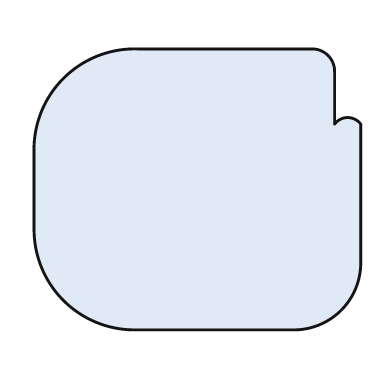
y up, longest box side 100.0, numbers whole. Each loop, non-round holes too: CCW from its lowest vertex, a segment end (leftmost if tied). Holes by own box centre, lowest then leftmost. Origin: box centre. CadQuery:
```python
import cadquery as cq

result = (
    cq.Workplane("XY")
    .moveTo(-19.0, -43.0)
    .lineTo(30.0, -43.0)
    .threePointArc((44.0, -37.0), (50.0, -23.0))
    .lineTo(50.0, 20.0)
    .threePointArc((46.0, 22.0), (42.0, 20.0))
    .lineTo(42.0, 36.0)
    .threePointArc((40.0, 41.0), (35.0, 43.0))
    .lineTo(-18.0, 43.0)
    .threePointArc((-41.0, 34.0), (-50.0, 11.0))
    .lineTo(-50.0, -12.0)
    .threePointArc((-41.0, -34.0), (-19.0, -43.0))
    .close()
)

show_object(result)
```